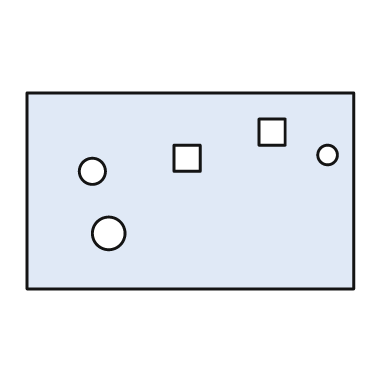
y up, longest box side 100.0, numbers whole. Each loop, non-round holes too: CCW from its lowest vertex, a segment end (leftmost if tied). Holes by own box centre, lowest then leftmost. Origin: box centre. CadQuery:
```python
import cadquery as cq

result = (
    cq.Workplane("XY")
    .moveTo(-50.0, -30.0)
    .lineTo(50.0, -30.0)
    .lineTo(50.0, 30.0)
    .lineTo(-50.0, 30.0)
    .close()
    .moveTo(-25.0, -13.0)
    .circle(5.0)
    .moveTo(-30.0, 6.0)
    .circle(4.0)
    .moveTo(-5.0, 6.0)
    .lineTo(3.0, 6.0)
    .lineTo(3.0, 14.0)
    .lineTo(-5.0, 14.0)
    .close()
    .moveTo(42.0, 11.0)
    .circle(3.0)
    .moveTo(21.0, 14.0)
    .lineTo(29.0, 14.0)
    .lineTo(29.0, 22.0)
    .lineTo(21.0, 22.0)
    .close()
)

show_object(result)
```